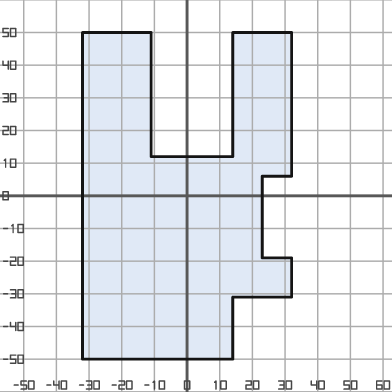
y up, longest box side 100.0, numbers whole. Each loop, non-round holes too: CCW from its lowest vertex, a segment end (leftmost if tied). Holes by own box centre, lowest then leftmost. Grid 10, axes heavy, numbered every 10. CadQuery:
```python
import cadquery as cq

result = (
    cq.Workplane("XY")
    .moveTo(-32.0, -50.0)
    .lineTo(14.0, -50.0)
    .lineTo(14.0, -31.0)
    .lineTo(32.0, -31.0)
    .lineTo(32.0, -19.0)
    .lineTo(23.0, -19.0)
    .lineTo(23.0, 6.0)
    .lineTo(32.0, 6.0)
    .lineTo(32.0, 50.0)
    .lineTo(14.0, 50.0)
    .lineTo(14.0, 12.0)
    .lineTo(-11.0, 12.0)
    .lineTo(-11.0, 50.0)
    .lineTo(-32.0, 50.0)
    .close()
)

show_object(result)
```